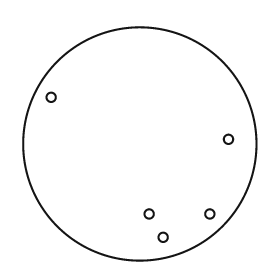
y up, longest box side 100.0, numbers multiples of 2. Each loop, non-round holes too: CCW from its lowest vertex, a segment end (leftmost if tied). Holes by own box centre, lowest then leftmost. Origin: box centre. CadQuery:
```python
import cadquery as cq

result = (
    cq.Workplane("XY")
    .moveTo(0.0, 0.0)
    .circle(50.0)
    .moveTo(10.0, -40.0)
    .circle(2.0)
    .moveTo(4.0, -30.0)
    .circle(2.0)
    .moveTo(30.0, -30.0)
    .circle(2.0)
    .moveTo(38.0, 2.0)
    .circle(2.0)
    .moveTo(-38.0, 20.0)
    .circle(2.0)
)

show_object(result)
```